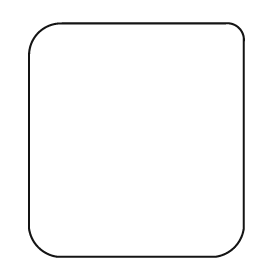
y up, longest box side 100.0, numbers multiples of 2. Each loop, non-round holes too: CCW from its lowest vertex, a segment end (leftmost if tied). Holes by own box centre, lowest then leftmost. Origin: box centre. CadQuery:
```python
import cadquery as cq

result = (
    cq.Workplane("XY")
    .moveTo(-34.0, -50.0)
    .lineTo(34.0, -50.0)
    .threePointArc((42.0, -46.0), (46.0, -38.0))
    .lineTo(46.0, 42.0)
    .threePointArc((44.0, 48.0), (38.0, 50.0))
    .lineTo(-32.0, 50.0)
    .threePointArc((-42.0, 46.0), (-46.0, 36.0))
    .lineTo(-46.0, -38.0)
    .threePointArc((-42.0, -46.0), (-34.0, -50.0))
    .close()
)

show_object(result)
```